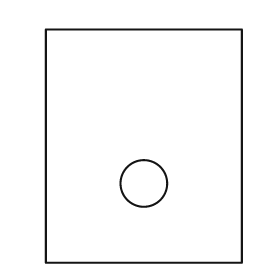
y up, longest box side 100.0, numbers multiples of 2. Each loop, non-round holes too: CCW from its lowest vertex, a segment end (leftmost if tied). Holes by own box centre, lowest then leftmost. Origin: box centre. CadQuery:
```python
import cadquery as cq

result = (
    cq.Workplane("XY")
    .moveTo(-42.0, -50.0)
    .lineTo(42.0, -50.0)
    .lineTo(42.0, 50.0)
    .lineTo(-42.0, 50.0)
    .close()
    .moveTo(0.0, -16.0)
    .circle(10.0)
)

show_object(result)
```